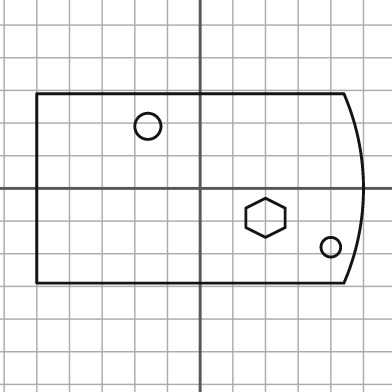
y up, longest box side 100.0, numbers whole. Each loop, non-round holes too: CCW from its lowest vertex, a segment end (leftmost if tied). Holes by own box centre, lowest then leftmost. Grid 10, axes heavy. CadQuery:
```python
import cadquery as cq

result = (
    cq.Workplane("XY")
    .moveTo(-50.0, -29.0)
    .lineTo(44.0, -29.0)
    .threePointArc((50.0, 0.0), (44.0, 29.0))
    .lineTo(-50.0, 29.0)
    .close()
    .moveTo(40.0, -18.0)
    .circle(3.0)
    .moveTo(20.0, -15.0)
    .lineTo(26.0, -12.0)
    .lineTo(26.0, -6.0)
    .lineTo(20.0, -3.0)
    .lineTo(14.0, -6.0)
    .lineTo(14.0, -12.0)
    .close()
    .moveTo(-16.0, 19.0)
    .circle(4.0)
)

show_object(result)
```